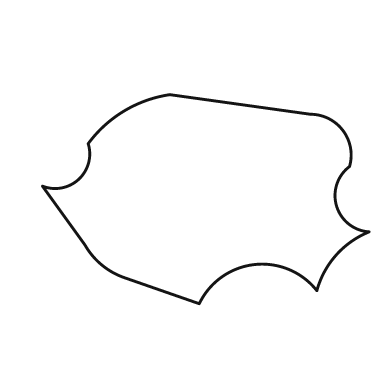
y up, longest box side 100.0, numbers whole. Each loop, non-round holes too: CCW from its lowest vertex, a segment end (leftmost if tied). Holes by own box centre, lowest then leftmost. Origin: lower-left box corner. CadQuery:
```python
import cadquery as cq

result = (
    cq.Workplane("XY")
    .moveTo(48.0, 0.0)
    .threePointArc((65.0, 12.0), (84.0, 4.0))
    .threePointArc((90.0, 15.0), (100.0, 22.0))
    .threePointArc((90.0, 30.0), (94.0, 42.0))
    .threePointArc((92.0, 53.0), (82.0, 58.0))
    .lineTo(39.0, 64.0)
    .threePointArc((25.0, 59.0), (14.0, 49.0))
    .threePointArc((11.0, 38.0), (0.0, 36.0))
    .lineTo(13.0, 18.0)
    .threePointArc((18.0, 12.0), (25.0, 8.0))
    .close()
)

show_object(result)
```